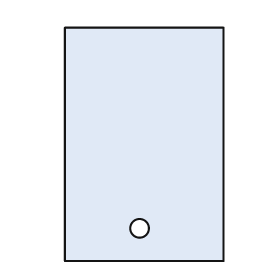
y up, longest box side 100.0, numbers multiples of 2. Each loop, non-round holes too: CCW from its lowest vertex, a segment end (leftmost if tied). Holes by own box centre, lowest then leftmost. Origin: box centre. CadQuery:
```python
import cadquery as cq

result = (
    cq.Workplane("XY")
    .moveTo(-34.0, -50.0)
    .lineTo(34.0, -50.0)
    .lineTo(34.0, 50.0)
    .lineTo(-34.0, 50.0)
    .close()
    .moveTo(-2.0, -36.0)
    .circle(4.0)
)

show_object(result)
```